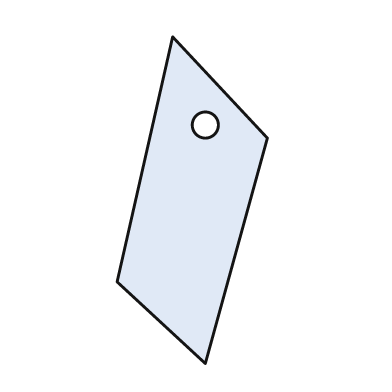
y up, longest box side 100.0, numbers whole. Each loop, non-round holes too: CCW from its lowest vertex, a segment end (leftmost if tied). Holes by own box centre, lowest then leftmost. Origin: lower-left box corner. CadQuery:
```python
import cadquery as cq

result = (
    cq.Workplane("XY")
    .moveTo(27.0, 0.0)
    .lineTo(46.0, 69.0)
    .lineTo(17.0, 100.0)
    .lineTo(0.0, 25.0)
    .close()
    .moveTo(27.0, 73.0)
    .circle(4.0)
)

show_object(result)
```